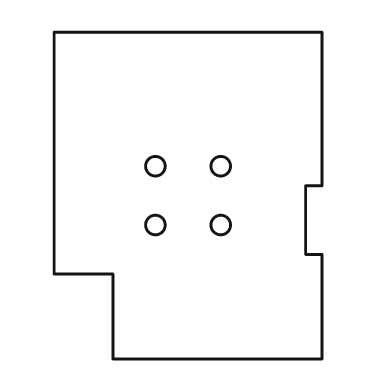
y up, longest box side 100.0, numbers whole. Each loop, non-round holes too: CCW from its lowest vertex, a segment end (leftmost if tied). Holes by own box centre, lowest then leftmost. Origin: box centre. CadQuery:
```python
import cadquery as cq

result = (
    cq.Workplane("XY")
    .moveTo(-23.0, -50.0)
    .lineTo(41.0, -50.0)
    .lineTo(41.0, -18.0)
    .lineTo(36.0, -18.0)
    .lineTo(36.0, 3.0)
    .lineTo(41.0, 3.0)
    .lineTo(41.0, 50.0)
    .lineTo(-41.0, 50.0)
    .lineTo(-41.0, -24.0)
    .lineTo(-23.0, -24.0)
    .close()
    .moveTo(-10.0, -9.0)
    .circle(3.0)
    .moveTo(10.0, -9.0)
    .circle(3.0)
    .moveTo(-10.0, 9.0)
    .circle(3.0)
    .moveTo(10.0, 9.0)
    .circle(3.0)
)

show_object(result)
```